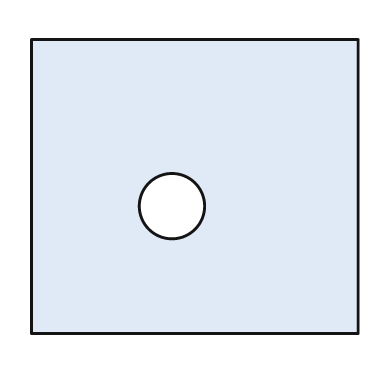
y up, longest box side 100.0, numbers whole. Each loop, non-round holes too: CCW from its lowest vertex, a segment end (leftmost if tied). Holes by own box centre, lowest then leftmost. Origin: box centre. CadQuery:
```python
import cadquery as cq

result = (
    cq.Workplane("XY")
    .moveTo(-50.0, -45.0)
    .lineTo(50.0, -45.0)
    .lineTo(50.0, 45.0)
    .lineTo(-50.0, 45.0)
    .close()
    .moveTo(-7.0, -6.0)
    .circle(10.0)
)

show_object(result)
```